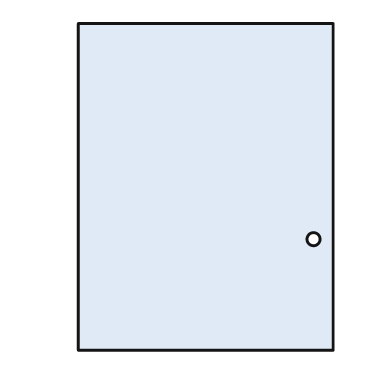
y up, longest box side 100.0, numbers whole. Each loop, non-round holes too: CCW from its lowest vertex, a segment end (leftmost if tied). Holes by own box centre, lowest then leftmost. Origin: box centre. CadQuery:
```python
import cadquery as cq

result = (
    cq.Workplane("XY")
    .moveTo(-39.0, -50.0)
    .lineTo(39.0, -50.0)
    .lineTo(39.0, 50.0)
    .lineTo(-39.0, 50.0)
    .close()
    .moveTo(33.0, -16.0)
    .circle(2.0)
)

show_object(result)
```